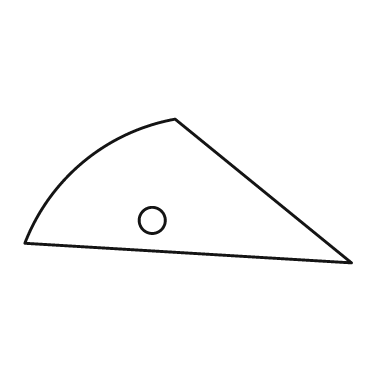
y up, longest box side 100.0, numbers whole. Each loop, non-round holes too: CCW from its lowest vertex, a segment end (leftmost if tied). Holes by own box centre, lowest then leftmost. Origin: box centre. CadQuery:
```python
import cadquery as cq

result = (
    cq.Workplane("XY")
    .moveTo(50.0, -22.0)
    .lineTo(-4.0, 22.0)
    .threePointArc((-32.0, 9.0), (-50.0, -16.0))
    .close()
    .moveTo(-11.0, -9.0)
    .circle(4.0)
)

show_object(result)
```